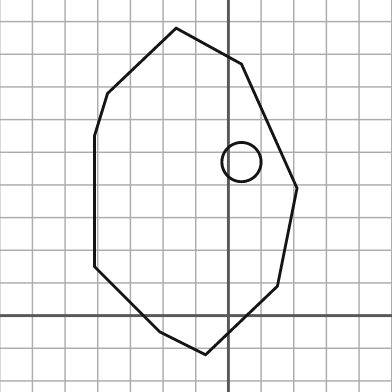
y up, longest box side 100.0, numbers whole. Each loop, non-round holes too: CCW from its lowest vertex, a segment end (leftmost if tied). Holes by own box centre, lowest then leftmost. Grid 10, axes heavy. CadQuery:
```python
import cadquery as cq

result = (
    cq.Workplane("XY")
    .moveTo(-7.0, -12.0)
    .lineTo(15.0, 9.0)
    .lineTo(21.0, 39.0)
    .lineTo(4.0, 77.0)
    .lineTo(-16.0, 88.0)
    .lineTo(-37.0, 68.0)
    .lineTo(-41.0, 55.0)
    .lineTo(-41.0, 15.0)
    .lineTo(-21.0, -5.0)
    .close()
    .moveTo(4.0, 47.0)
    .circle(6.0)
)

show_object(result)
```